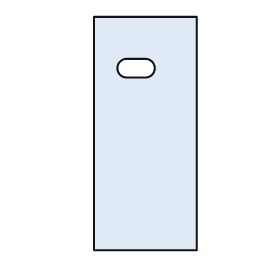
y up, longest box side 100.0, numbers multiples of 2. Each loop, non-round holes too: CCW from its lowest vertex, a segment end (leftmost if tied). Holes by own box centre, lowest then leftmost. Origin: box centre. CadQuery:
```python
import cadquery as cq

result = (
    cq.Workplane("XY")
    .moveTo(-22.0, -50.0)
    .lineTo(22.0, -50.0)
    .lineTo(22.0, 50.0)
    .lineTo(-22.0, 50.0)
    .close()
    .moveTo(-8.0, 24.0)
    .lineTo(0.0, 24.0)
    .threePointArc((4.0, 28.0), (0.0, 32.0))
    .lineTo(-8.0, 32.0)
    .threePointArc((-12.0, 28.0), (-8.0, 24.0))
    .close()
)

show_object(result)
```